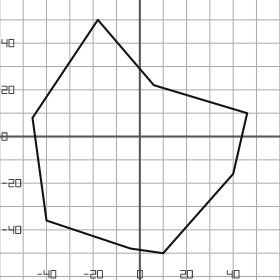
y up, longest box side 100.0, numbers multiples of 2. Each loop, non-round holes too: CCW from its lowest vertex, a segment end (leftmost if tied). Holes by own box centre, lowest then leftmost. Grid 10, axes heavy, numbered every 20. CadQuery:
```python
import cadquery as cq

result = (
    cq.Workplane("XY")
    .moveTo(10.0, -50.0)
    .lineTo(40.0, -16.0)
    .lineTo(46.0, 10.0)
    .lineTo(6.0, 22.0)
    .lineTo(-18.0, 50.0)
    .lineTo(-46.0, 8.0)
    .lineTo(-40.0, -36.0)
    .lineTo(-4.0, -48.0)
    .close()
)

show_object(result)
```